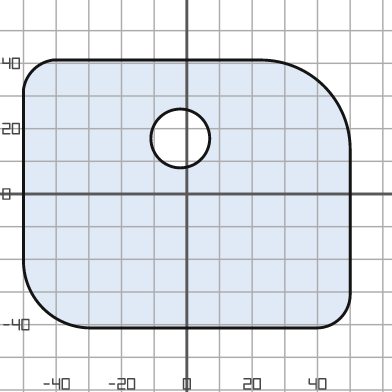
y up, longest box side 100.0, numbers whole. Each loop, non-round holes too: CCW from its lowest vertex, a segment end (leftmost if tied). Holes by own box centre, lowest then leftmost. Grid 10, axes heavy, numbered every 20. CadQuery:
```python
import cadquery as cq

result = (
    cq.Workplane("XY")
    .moveTo(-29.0, -41.0)
    .lineTo(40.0, -41.0)
    .threePointArc((47.0, -38.0), (50.0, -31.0))
    .lineTo(50.0, 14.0)
    .threePointArc((42.0, 33.0), (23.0, 41.0))
    .lineTo(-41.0, 41.0)
    .threePointArc((-47.0, 38.0), (-50.0, 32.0))
    .lineTo(-50.0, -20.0)
    .threePointArc((-44.0, -35.0), (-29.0, -41.0))
    .close()
    .moveTo(-2.0, 17.0)
    .circle(9.0)
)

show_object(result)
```